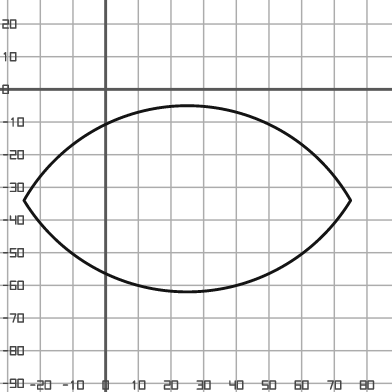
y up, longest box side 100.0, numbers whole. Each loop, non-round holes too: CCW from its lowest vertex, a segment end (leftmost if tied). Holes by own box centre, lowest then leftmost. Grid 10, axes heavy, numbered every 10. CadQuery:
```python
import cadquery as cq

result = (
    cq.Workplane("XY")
    .moveTo(-25.0, -34.0)
    .threePointArc((25.0, -62.0), (75.0, -34.0))
    .threePointArc((25.0, -5.0), (-25.0, -34.0))
    .close()
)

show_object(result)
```